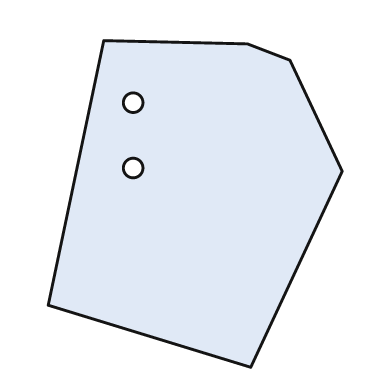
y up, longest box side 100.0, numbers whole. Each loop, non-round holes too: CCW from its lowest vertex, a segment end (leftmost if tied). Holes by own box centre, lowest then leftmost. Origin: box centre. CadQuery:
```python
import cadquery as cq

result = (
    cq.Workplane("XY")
    .moveTo(17.0, -50.0)
    .lineTo(45.0, 10.0)
    .lineTo(29.0, 44.0)
    .lineTo(16.0, 49.0)
    .lineTo(-28.0, 50.0)
    .lineTo(-45.0, -31.0)
    .close()
    .moveTo(-19.0, 11.0)
    .circle(3.0)
    .moveTo(-19.0, 31.0)
    .circle(3.0)
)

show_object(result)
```